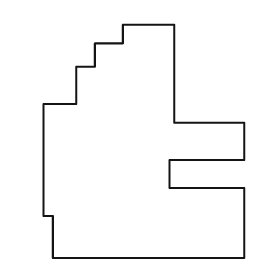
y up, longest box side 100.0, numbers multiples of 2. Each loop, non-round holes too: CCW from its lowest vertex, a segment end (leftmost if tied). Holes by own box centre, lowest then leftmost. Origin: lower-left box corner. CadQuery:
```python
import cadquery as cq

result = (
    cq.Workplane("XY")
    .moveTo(4.0, 0.0)
    .lineTo(86.0, 0.0)
    .lineTo(86.0, 30.0)
    .lineTo(54.0, 30.0)
    .lineTo(54.0, 42.0)
    .lineTo(86.0, 42.0)
    .lineTo(86.0, 58.0)
    .lineTo(56.0, 58.0)
    .lineTo(56.0, 100.0)
    .lineTo(34.0, 100.0)
    .lineTo(34.0, 92.0)
    .lineTo(22.0, 92.0)
    .lineTo(22.0, 82.0)
    .lineTo(14.0, 82.0)
    .lineTo(14.0, 66.0)
    .lineTo(0.0, 66.0)
    .lineTo(0.0, 18.0)
    .lineTo(4.0, 18.0)
    .close()
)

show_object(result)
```